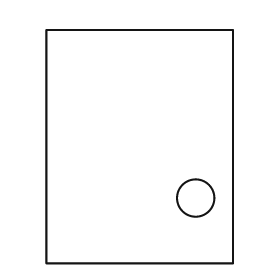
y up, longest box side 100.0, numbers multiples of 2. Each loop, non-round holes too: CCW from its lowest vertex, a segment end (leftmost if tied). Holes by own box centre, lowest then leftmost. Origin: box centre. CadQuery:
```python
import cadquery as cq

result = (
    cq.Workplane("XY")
    .moveTo(-40.0, -50.0)
    .lineTo(40.0, -50.0)
    .lineTo(40.0, 50.0)
    .lineTo(-40.0, 50.0)
    .close()
    .moveTo(24.0, -22.0)
    .circle(8.0)
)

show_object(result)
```